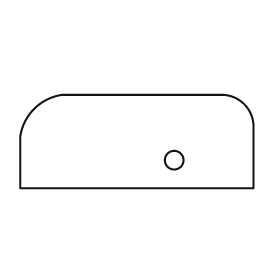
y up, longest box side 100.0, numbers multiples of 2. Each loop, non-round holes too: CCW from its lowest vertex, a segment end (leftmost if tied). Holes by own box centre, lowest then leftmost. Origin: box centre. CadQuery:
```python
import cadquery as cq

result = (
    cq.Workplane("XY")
    .moveTo(-50.0, -20.0)
    .lineTo(50.0, -20.0)
    .lineTo(50.0, 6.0)
    .threePointArc((46.0, 16.0), (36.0, 20.0))
    .lineTo(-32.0, 20.0)
    .threePointArc((-44.0, 14.0), (-50.0, 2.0))
    .close()
    .moveTo(16.0, -8.0)
    .circle(4.0)
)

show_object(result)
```